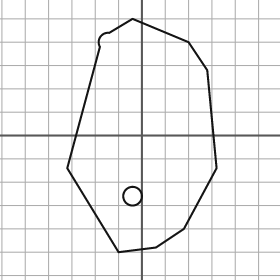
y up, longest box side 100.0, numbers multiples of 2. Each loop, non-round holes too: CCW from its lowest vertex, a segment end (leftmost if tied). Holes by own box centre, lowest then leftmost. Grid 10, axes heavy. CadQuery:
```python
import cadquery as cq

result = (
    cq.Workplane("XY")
    .moveTo(-10.0, -50.0)
    .lineTo(6.0, -48.0)
    .lineTo(18.0, -40.0)
    .lineTo(32.0, -14.0)
    .lineTo(28.0, 28.0)
    .lineTo(20.0, 40.0)
    .lineTo(-4.0, 50.0)
    .lineTo(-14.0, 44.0)
    .threePointArc((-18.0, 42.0), (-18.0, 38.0))
    .lineTo(-32.0, -14.0)
    .close()
    .moveTo(-4.0, -26.0)
    .circle(4.0)
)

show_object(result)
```